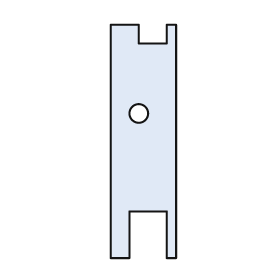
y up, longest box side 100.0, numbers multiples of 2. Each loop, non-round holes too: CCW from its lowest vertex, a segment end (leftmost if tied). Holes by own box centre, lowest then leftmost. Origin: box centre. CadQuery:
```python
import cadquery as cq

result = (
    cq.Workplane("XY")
    .moveTo(-14.0, -50.0)
    .lineTo(-6.0, -50.0)
    .lineTo(-6.0, -30.0)
    .lineTo(10.0, -30.0)
    .lineTo(10.0, -50.0)
    .lineTo(14.0, -50.0)
    .lineTo(14.0, 50.0)
    .lineTo(10.0, 50.0)
    .lineTo(10.0, 42.0)
    .lineTo(-2.0, 42.0)
    .lineTo(-2.0, 50.0)
    .lineTo(-14.0, 50.0)
    .close()
    .moveTo(-2.0, 12.0)
    .circle(4.0)
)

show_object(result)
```